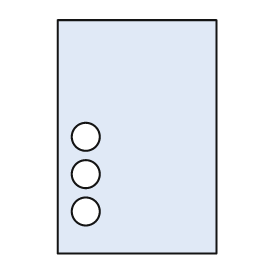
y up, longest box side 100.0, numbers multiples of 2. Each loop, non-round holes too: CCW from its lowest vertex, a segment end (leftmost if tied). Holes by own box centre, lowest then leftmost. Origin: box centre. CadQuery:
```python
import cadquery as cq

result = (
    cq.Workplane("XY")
    .moveTo(-34.0, -50.0)
    .lineTo(34.0, -50.0)
    .lineTo(34.0, 50.0)
    .lineTo(-34.0, 50.0)
    .close()
    .moveTo(-22.0, -32.0)
    .circle(6.0)
    .moveTo(-22.0, -16.0)
    .circle(6.0)
    .moveTo(-22.0, 0.0)
    .circle(6.0)
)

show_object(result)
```